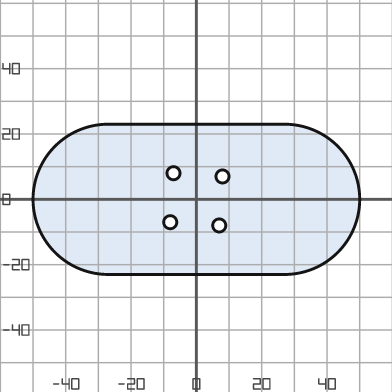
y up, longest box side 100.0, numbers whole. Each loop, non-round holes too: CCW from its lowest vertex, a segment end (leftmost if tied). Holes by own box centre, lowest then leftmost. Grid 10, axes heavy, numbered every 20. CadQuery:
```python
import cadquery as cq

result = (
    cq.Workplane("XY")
    .moveTo(-27.0, -23.0)
    .lineTo(27.0, -23.0)
    .threePointArc((50.0, 0.0), (27.0, 23.0))
    .lineTo(-27.0, 23.0)
    .threePointArc((-50.0, 0.0), (-27.0, -23.0))
    .close()
    .moveTo(7.0, -8.0)
    .circle(2.0)
    .moveTo(-8.0, -7.0)
    .circle(2.0)
    .moveTo(8.0, 7.0)
    .circle(2.0)
    .moveTo(-7.0, 8.0)
    .circle(2.0)
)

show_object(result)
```